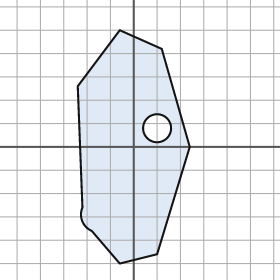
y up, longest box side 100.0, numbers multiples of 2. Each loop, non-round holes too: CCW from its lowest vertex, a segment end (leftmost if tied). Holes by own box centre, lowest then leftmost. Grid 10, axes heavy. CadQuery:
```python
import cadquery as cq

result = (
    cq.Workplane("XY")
    .moveTo(-6.0, -50.0)
    .lineTo(10.0, -46.0)
    .lineTo(24.0, 0.0)
    .lineTo(12.0, 42.0)
    .lineTo(-6.0, 50.0)
    .lineTo(-24.0, 26.0)
    .lineTo(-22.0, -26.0)
    .threePointArc((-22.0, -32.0), (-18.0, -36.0))
    .close()
    .moveTo(10.0, 8.0)
    .circle(6.0)
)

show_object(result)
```